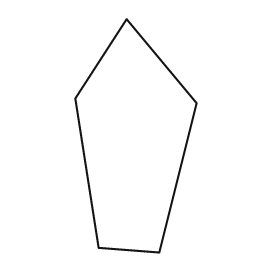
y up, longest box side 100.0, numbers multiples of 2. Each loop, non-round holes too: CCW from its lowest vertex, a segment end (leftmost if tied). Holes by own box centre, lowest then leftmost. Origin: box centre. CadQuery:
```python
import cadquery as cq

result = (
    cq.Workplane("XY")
    .moveTo(10.0, -50.0)
    .lineTo(26.0, 14.0)
    .lineTo(-4.0, 50.0)
    .lineTo(-26.0, 16.0)
    .lineTo(-16.0, -48.0)
    .close()
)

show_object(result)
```